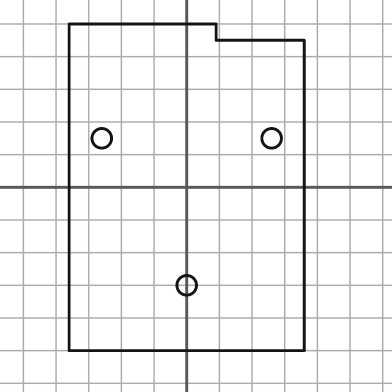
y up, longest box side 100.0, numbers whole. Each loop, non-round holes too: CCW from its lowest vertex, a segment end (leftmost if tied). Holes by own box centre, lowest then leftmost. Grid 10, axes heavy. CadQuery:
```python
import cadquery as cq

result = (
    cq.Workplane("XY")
    .moveTo(-36.0, -50.0)
    .lineTo(36.0, -50.0)
    .lineTo(36.0, 45.0)
    .lineTo(9.0, 45.0)
    .lineTo(9.0, 50.0)
    .lineTo(-36.0, 50.0)
    .close()
    .moveTo(0.0, -30.0)
    .circle(3.0)
    .moveTo(-26.0, 15.0)
    .circle(3.0)
    .moveTo(26.0, 15.0)
    .circle(3.0)
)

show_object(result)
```